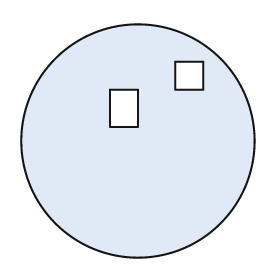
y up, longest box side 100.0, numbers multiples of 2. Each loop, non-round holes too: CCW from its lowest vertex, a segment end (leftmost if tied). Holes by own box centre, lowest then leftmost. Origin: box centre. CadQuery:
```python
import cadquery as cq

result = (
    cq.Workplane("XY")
    .moveTo(0.0, 0.0)
    .circle(50.0)
    .moveTo(-12.0, 6.0)
    .lineTo(0.0, 6.0)
    .lineTo(0.0, 22.0)
    .lineTo(-12.0, 22.0)
    .close()
    .moveTo(16.0, 22.0)
    .lineTo(28.0, 22.0)
    .lineTo(28.0, 34.0)
    .lineTo(16.0, 34.0)
    .close()
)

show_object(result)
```